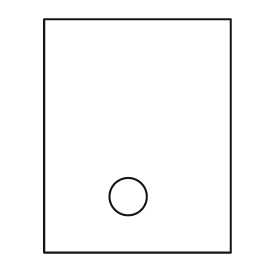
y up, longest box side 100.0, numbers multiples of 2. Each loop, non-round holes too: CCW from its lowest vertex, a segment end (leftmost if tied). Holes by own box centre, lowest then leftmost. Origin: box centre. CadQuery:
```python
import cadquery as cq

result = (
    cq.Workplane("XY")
    .moveTo(-40.0, -50.0)
    .lineTo(40.0, -50.0)
    .lineTo(40.0, 50.0)
    .lineTo(-40.0, 50.0)
    .close()
    .moveTo(-4.0, -26.0)
    .circle(8.0)
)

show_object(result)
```